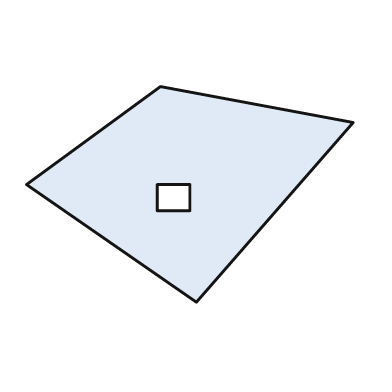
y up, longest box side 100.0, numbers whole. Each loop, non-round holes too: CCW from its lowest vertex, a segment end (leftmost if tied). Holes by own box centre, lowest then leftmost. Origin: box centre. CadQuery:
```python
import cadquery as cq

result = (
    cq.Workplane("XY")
    .moveTo(2.0, -33.0)
    .lineTo(50.0, 22.0)
    .lineTo(-9.0, 33.0)
    .lineTo(-50.0, 3.0)
    .close()
    .moveTo(-10.0, -5.0)
    .lineTo(0.0, -5.0)
    .lineTo(0.0, 3.0)
    .lineTo(-10.0, 3.0)
    .close()
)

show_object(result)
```